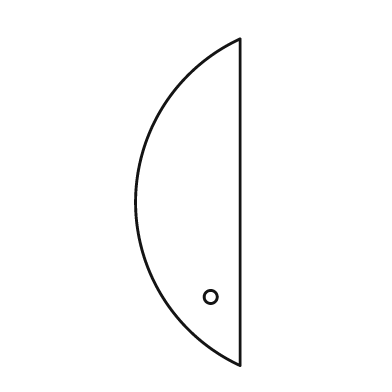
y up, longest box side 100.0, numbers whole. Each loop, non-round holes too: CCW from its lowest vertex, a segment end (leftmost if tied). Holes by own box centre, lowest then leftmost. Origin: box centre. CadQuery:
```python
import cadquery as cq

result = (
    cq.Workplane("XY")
    .moveTo(16.0, -50.0)
    .lineTo(16.0, 50.0)
    .threePointArc((-16.0, 0.0), (16.0, -50.0))
    .close()
    .moveTo(7.0, -29.0)
    .circle(2.0)
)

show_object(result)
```